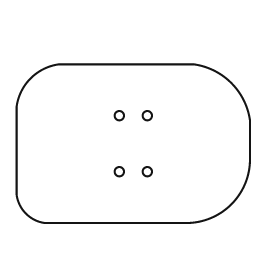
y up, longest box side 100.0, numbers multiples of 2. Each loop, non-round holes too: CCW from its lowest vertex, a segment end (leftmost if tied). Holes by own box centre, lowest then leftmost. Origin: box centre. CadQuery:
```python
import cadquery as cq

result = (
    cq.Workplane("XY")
    .moveTo(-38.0, -34.0)
    .lineTo(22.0, -34.0)
    .threePointArc((42.0, -26.0), (50.0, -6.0))
    .lineTo(50.0, 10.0)
    .threePointArc((42.0, 26.0), (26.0, 34.0))
    .lineTo(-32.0, 34.0)
    .threePointArc((-44.0, 28.0), (-50.0, 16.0))
    .lineTo(-50.0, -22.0)
    .threePointArc((-46.0, -30.0), (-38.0, -34.0))
    .close()
    .moveTo(-6.0, -12.0)
    .circle(2.0)
    .moveTo(6.0, -12.0)
    .circle(2.0)
    .moveTo(-6.0, 12.0)
    .circle(2.0)
    .moveTo(6.0, 12.0)
    .circle(2.0)
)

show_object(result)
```